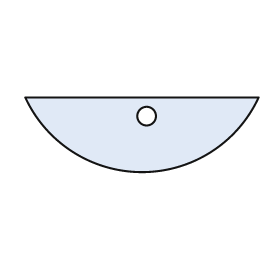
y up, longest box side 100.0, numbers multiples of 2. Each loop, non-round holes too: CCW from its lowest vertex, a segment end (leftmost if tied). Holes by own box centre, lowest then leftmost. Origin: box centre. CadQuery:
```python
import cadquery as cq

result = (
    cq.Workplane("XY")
    .moveTo(-50.0, 16.0)
    .threePointArc((0.0, -16.0), (50.0, 16.0))
    .close()
    .moveTo(2.0, 8.0)
    .circle(4.0)
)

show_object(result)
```